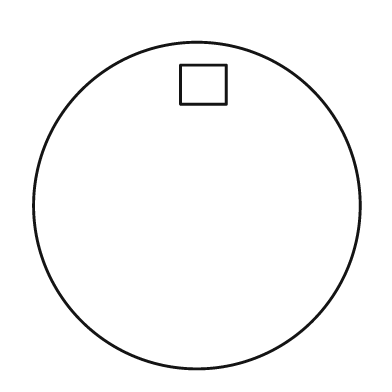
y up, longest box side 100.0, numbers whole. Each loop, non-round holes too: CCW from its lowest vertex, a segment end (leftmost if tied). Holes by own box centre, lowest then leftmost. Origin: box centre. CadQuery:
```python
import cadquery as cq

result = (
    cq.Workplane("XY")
    .moveTo(0.0, 0.0)
    .circle(50.0)
    .moveTo(-5.0, 31.0)
    .lineTo(9.0, 31.0)
    .lineTo(9.0, 43.0)
    .lineTo(-5.0, 43.0)
    .close()
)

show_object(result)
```